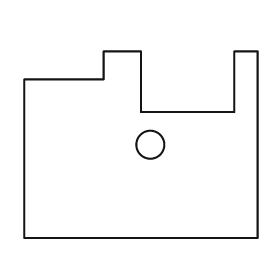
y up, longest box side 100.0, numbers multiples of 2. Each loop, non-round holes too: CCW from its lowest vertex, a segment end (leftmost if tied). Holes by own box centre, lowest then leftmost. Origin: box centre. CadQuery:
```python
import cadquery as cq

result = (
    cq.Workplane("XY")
    .moveTo(-50.0, -40.0)
    .lineTo(50.0, -40.0)
    .lineTo(50.0, 40.0)
    .lineTo(40.0, 40.0)
    .lineTo(40.0, 14.0)
    .lineTo(0.0, 14.0)
    .lineTo(0.0, 40.0)
    .lineTo(-16.0, 40.0)
    .lineTo(-16.0, 28.0)
    .lineTo(-50.0, 28.0)
    .close()
    .moveTo(4.0, 0.0)
    .circle(6.0)
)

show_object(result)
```